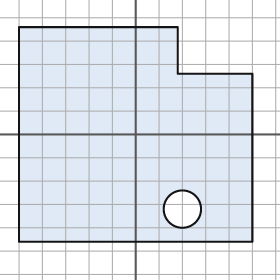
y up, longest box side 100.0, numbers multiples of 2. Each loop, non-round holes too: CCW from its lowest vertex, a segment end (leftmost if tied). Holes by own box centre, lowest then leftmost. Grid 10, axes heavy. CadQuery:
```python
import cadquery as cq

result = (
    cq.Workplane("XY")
    .moveTo(-50.0, -46.0)
    .lineTo(50.0, -46.0)
    .lineTo(50.0, 26.0)
    .lineTo(18.0, 26.0)
    .lineTo(18.0, 46.0)
    .lineTo(-50.0, 46.0)
    .close()
    .moveTo(20.0, -32.0)
    .circle(8.0)
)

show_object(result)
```